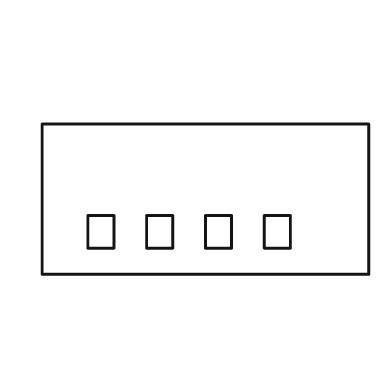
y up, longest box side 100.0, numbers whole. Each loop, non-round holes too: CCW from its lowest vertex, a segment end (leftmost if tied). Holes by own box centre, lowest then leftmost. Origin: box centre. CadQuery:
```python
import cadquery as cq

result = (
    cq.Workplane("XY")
    .moveTo(-50.0, -23.0)
    .lineTo(50.0, -23.0)
    .lineTo(50.0, 23.0)
    .lineTo(-50.0, 23.0)
    .close()
    .moveTo(-36.0, -15.0)
    .lineTo(-28.0, -15.0)
    .lineTo(-28.0, -5.0)
    .lineTo(-36.0, -5.0)
    .close()
    .moveTo(-18.0, -15.0)
    .lineTo(-10.0, -15.0)
    .lineTo(-10.0, -5.0)
    .lineTo(-18.0, -5.0)
    .close()
    .moveTo(0.0, -15.0)
    .lineTo(8.0, -15.0)
    .lineTo(8.0, -5.0)
    .lineTo(0.0, -5.0)
    .close()
    .moveTo(18.0, -15.0)
    .lineTo(26.0, -15.0)
    .lineTo(26.0, -5.0)
    .lineTo(18.0, -5.0)
    .close()
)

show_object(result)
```